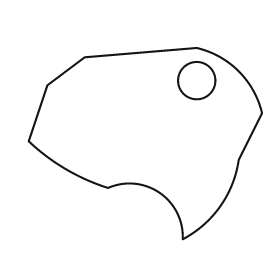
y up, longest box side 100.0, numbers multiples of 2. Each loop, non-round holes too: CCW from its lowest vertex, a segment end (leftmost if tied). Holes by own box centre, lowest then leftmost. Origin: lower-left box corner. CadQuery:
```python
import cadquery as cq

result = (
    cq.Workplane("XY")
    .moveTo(66.0, 0.0)
    .threePointArc((82.0, 14.0), (90.0, 34.0))
    .lineTo(100.0, 54.0)
    .threePointArc((90.0, 72.0), (72.0, 82.0))
    .lineTo(24.0, 78.0)
    .lineTo(8.0, 66.0)
    .lineTo(0.0, 42.0)
    .threePointArc((16.0, 30.0), (34.0, 22.0))
    .threePointArc((56.0, 20.0), (66.0, 0.0))
    .close()
    .moveTo(72.0, 68.0)
    .circle(8.0)
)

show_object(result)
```